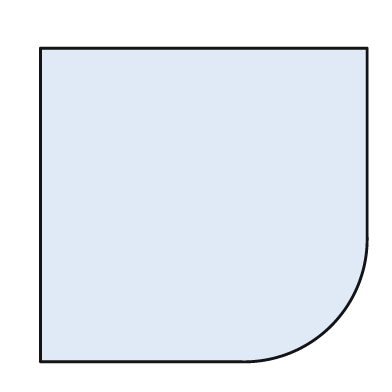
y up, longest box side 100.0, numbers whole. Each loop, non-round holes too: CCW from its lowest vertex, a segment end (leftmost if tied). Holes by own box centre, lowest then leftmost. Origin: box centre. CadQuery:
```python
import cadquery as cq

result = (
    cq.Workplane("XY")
    .moveTo(-50.0, -48.0)
    .lineTo(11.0, -48.0)
    .threePointArc((39.0, -37.0), (50.0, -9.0))
    .lineTo(50.0, 48.0)
    .lineTo(-50.0, 48.0)
    .close()
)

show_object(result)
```